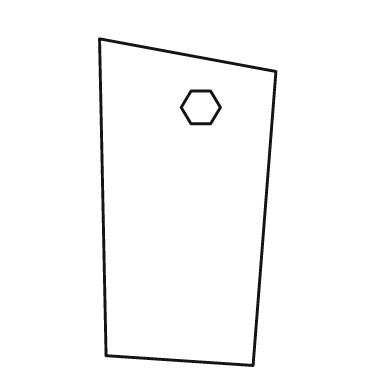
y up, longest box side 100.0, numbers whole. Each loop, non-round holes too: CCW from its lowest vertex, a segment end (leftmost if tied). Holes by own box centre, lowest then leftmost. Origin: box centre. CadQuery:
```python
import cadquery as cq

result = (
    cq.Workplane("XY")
    .moveTo(20.0, -50.0)
    .lineTo(27.0, 40.0)
    .lineTo(-27.0, 50.0)
    .lineTo(-25.0, -47.0)
    .close()
    .moveTo(1.0, 24.0)
    .lineTo(7.0, 24.0)
    .lineTo(10.0, 29.0)
    .lineTo(7.0, 34.0)
    .lineTo(1.0, 34.0)
    .lineTo(-2.0, 29.0)
    .close()
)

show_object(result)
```